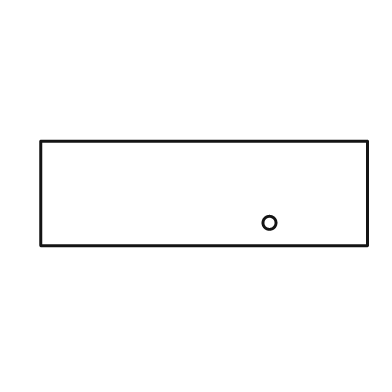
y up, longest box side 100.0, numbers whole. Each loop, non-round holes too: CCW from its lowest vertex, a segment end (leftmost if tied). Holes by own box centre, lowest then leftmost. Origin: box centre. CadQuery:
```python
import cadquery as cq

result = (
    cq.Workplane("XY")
    .moveTo(-50.0, -16.0)
    .lineTo(50.0, -16.0)
    .lineTo(50.0, 16.0)
    .lineTo(-50.0, 16.0)
    .close()
    .moveTo(20.0, -9.0)
    .circle(2.0)
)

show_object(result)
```